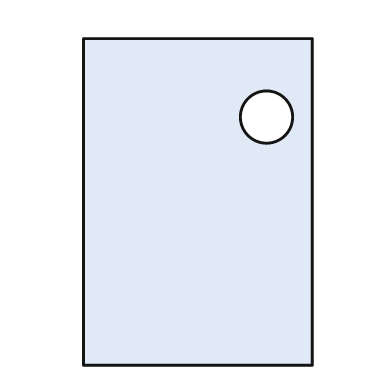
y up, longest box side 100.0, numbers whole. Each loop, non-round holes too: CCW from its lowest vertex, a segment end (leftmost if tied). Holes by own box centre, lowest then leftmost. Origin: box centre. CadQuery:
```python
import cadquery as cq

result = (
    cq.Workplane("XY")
    .moveTo(-35.0, -50.0)
    .lineTo(35.0, -50.0)
    .lineTo(35.0, 50.0)
    .lineTo(-35.0, 50.0)
    .close()
    .moveTo(21.0, 26.0)
    .circle(8.0)
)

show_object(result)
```